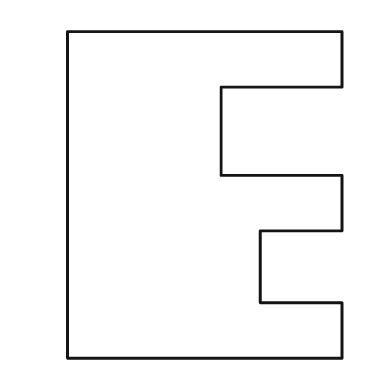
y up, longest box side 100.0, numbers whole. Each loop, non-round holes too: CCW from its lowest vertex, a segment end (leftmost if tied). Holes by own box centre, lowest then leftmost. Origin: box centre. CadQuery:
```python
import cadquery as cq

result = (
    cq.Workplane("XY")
    .moveTo(-42.0, -50.0)
    .lineTo(42.0, -50.0)
    .lineTo(42.0, -33.0)
    .lineTo(17.0, -33.0)
    .lineTo(17.0, -11.0)
    .lineTo(42.0, -11.0)
    .lineTo(42.0, 6.0)
    .lineTo(5.0, 6.0)
    .lineTo(5.0, 33.0)
    .lineTo(42.0, 33.0)
    .lineTo(42.0, 50.0)
    .lineTo(-42.0, 50.0)
    .close()
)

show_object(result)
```